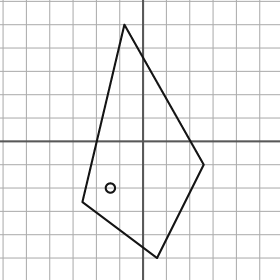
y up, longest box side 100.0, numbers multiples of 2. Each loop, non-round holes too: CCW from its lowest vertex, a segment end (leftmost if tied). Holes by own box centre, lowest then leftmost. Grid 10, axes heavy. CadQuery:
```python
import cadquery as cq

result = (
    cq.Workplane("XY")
    .moveTo(6.0, -50.0)
    .lineTo(26.0, -10.0)
    .lineTo(-8.0, 50.0)
    .lineTo(-26.0, -26.0)
    .close()
    .moveTo(-14.0, -20.0)
    .circle(2.0)
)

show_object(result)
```